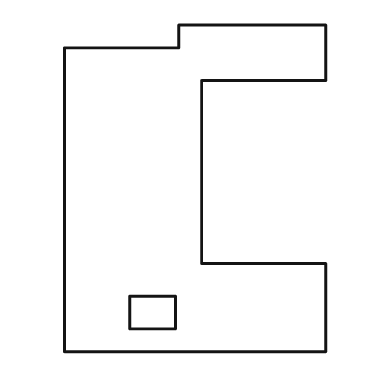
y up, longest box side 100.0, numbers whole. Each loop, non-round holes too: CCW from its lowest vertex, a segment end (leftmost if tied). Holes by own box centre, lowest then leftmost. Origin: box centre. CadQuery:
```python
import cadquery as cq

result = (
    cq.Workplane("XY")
    .moveTo(-40.0, -50.0)
    .lineTo(40.0, -50.0)
    .lineTo(40.0, -23.0)
    .lineTo(2.0, -23.0)
    .lineTo(2.0, 33.0)
    .lineTo(40.0, 33.0)
    .lineTo(40.0, 50.0)
    .lineTo(-5.0, 50.0)
    .lineTo(-5.0, 43.0)
    .lineTo(-40.0, 43.0)
    .close()
    .moveTo(-20.0, -43.0)
    .lineTo(-6.0, -43.0)
    .lineTo(-6.0, -33.0)
    .lineTo(-20.0, -33.0)
    .close()
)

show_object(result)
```